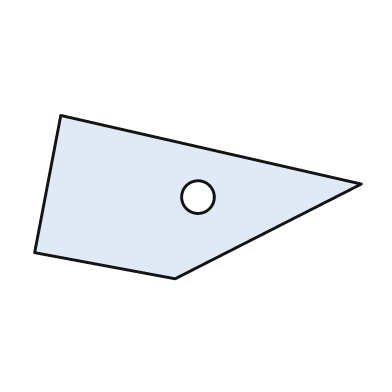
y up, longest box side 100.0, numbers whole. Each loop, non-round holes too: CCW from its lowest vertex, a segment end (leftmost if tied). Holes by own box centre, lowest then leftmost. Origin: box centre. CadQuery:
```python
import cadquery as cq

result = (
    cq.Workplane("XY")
    .moveTo(-7.0, -25.0)
    .lineTo(50.0, 4.0)
    .lineTo(-42.0, 25.0)
    .lineTo(-50.0, -17.0)
    .close()
    .moveTo(0.0, 0.0)
    .circle(5.0)
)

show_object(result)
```